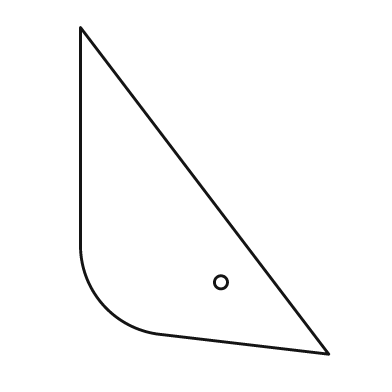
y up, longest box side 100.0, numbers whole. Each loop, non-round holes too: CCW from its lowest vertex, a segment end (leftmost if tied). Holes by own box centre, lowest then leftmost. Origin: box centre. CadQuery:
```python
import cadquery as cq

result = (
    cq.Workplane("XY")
    .moveTo(38.0, -50.0)
    .lineTo(-38.0, 50.0)
    .lineTo(-38.0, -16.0)
    .threePointArc((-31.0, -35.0), (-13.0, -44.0))
    .close()
    .moveTo(5.0, -28.0)
    .circle(2.0)
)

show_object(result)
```